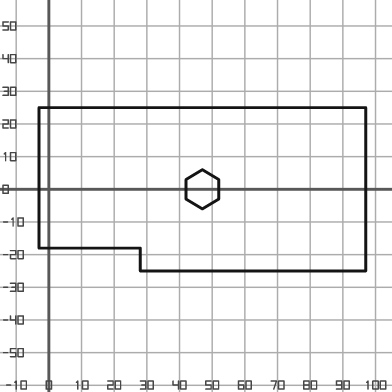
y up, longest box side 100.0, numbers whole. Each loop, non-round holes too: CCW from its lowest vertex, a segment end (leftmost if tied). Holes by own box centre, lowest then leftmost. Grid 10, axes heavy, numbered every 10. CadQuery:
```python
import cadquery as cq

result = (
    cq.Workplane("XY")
    .moveTo(28.0, -25.0)
    .lineTo(97.0, -25.0)
    .lineTo(97.0, 25.0)
    .lineTo(-3.0, 25.0)
    .lineTo(-3.0, -18.0)
    .lineTo(28.0, -18.0)
    .close()
    .moveTo(47.0, -6.0)
    .lineTo(52.0, -3.0)
    .lineTo(52.0, 3.0)
    .lineTo(47.0, 6.0)
    .lineTo(42.0, 3.0)
    .lineTo(42.0, -3.0)
    .close()
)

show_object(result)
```